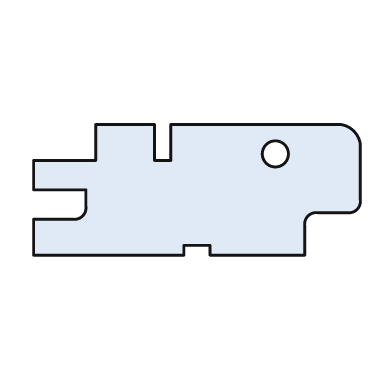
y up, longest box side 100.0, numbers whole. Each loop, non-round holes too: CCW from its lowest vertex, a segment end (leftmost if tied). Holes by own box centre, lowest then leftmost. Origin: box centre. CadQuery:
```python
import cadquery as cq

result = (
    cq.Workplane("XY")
    .moveTo(-50.0, -20.0)
    .lineTo(-4.0, -20.0)
    .lineTo(-4.0, -17.0)
    .lineTo(4.0, -17.0)
    .lineTo(4.0, -20.0)
    .lineTo(33.0, -20.0)
    .lineTo(33.0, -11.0)
    .threePointArc((34.0, -8.0), (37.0, -7.0))
    .lineTo(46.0, -7.0)
    .threePointArc((49.0, -6.0), (50.0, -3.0))
    .lineTo(50.0, 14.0)
    .threePointArc((48.0, 18.0), (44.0, 20.0))
    .lineTo(-8.0, 20.0)
    .lineTo(-8.0, 9.0)
    .lineTo(-13.0, 9.0)
    .lineTo(-13.0, 20.0)
    .lineTo(-31.0, 20.0)
    .lineTo(-31.0, 9.0)
    .lineTo(-50.0, 9.0)
    .lineTo(-50.0, 0.0)
    .lineTo(-34.0, 0.0)
    .lineTo(-34.0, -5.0)
    .threePointArc((-35.0, -8.0), (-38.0, -9.0))
    .lineTo(-50.0, -9.0)
    .close()
    .moveTo(24.0, 11.0)
    .circle(4.0)
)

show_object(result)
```